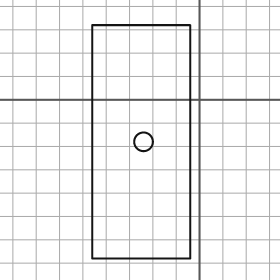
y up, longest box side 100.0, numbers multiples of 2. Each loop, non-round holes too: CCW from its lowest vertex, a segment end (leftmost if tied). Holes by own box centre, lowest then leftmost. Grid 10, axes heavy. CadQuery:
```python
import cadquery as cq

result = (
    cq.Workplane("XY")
    .moveTo(-46.0, -68.0)
    .lineTo(-4.0, -68.0)
    .lineTo(-4.0, 32.0)
    .lineTo(-46.0, 32.0)
    .close()
    .moveTo(-24.0, -18.0)
    .circle(4.0)
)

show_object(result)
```